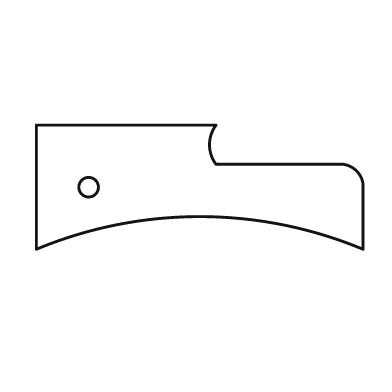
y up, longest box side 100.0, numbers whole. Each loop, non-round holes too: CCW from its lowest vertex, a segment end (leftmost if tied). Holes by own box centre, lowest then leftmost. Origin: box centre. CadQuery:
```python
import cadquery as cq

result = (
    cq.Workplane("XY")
    .moveTo(-50.0, -19.0)
    .threePointArc((0.0, -9.0), (50.0, -19.0))
    .lineTo(50.0, 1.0)
    .threePointArc((48.0, 5.0), (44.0, 7.0))
    .lineTo(5.0, 7.0)
    .threePointArc((3.0, 13.0), (5.0, 19.0))
    .lineTo(-50.0, 19.0)
    .close()
    .moveTo(-34.0, 0.0)
    .circle(3.0)
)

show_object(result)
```